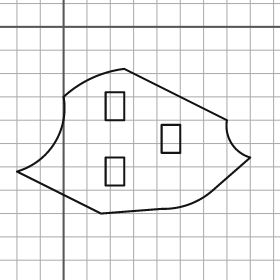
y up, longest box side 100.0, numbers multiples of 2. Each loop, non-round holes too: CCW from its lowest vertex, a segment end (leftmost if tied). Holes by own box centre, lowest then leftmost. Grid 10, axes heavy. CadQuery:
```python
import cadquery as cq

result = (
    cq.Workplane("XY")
    .moveTo(16.0, -80.0)
    .lineTo(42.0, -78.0)
    .threePointArc((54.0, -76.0), (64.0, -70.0))
    .lineTo(80.0, -56.0)
    .threePointArc((72.0, -50.0), (70.0, -40.0))
    .lineTo(26.0, -18.0)
    .threePointArc((12.0, -22.0), (0.0, -30.0))
    .threePointArc((-4.0, -50.0), (-20.0, -62.0))
    .close()
    .moveTo(18.0, -68.0)
    .lineTo(26.0, -68.0)
    .lineTo(26.0, -56.0)
    .lineTo(18.0, -56.0)
    .close()
    .moveTo(42.0, -54.0)
    .lineTo(50.0, -54.0)
    .lineTo(50.0, -42.0)
    .lineTo(42.0, -42.0)
    .close()
    .moveTo(18.0, -40.0)
    .lineTo(26.0, -40.0)
    .lineTo(26.0, -28.0)
    .lineTo(18.0, -28.0)
    .close()
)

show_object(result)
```